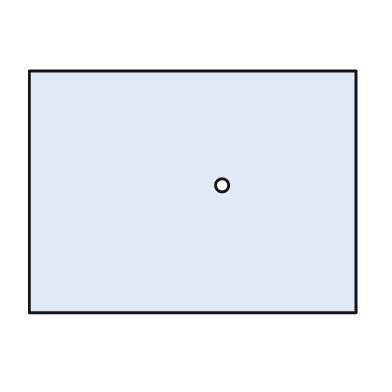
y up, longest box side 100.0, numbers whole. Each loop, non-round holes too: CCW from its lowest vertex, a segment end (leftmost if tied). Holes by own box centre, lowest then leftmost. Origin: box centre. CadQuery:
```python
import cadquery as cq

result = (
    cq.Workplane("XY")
    .moveTo(-50.0, -37.0)
    .lineTo(50.0, -37.0)
    .lineTo(50.0, 37.0)
    .lineTo(-50.0, 37.0)
    .close()
    .moveTo(9.0, 2.0)
    .circle(2.0)
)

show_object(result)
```